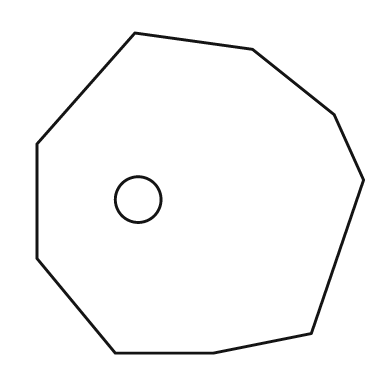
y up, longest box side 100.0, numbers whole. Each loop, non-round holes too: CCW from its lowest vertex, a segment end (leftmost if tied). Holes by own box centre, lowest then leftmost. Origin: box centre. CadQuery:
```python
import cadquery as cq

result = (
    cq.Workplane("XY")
    .moveTo(-26.0, -49.0)
    .lineTo(4.0, -49.0)
    .lineTo(34.0, -43.0)
    .lineTo(50.0, 4.0)
    .lineTo(41.0, 24.0)
    .lineTo(16.0, 44.0)
    .lineTo(-20.0, 49.0)
    .lineTo(-50.0, 15.0)
    .lineTo(-50.0, -20.0)
    .close()
    .moveTo(-19.0, -2.0)
    .circle(7.0)
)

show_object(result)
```